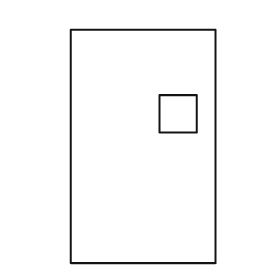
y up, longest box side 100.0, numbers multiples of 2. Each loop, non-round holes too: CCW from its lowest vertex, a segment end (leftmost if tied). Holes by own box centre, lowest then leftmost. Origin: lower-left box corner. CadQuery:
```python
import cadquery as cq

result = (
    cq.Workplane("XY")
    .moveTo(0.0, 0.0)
    .lineTo(62.0, 0.0)
    .lineTo(62.0, 100.0)
    .lineTo(0.0, 100.0)
    .close()
    .moveTo(38.0, 56.0)
    .lineTo(54.0, 56.0)
    .lineTo(54.0, 72.0)
    .lineTo(38.0, 72.0)
    .close()
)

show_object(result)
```